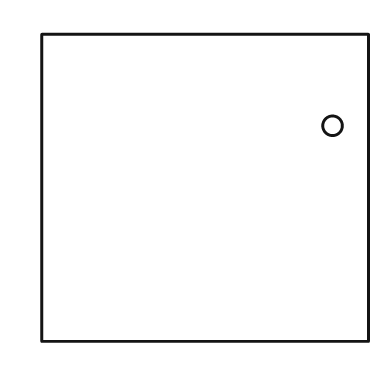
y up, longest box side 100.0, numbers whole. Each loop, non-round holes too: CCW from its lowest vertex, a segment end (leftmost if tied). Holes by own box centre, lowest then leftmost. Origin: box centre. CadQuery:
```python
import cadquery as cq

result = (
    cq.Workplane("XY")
    .moveTo(-50.0, -47.0)
    .lineTo(50.0, -47.0)
    .lineTo(50.0, 47.0)
    .lineTo(-50.0, 47.0)
    .close()
    .moveTo(39.0, 19.0)
    .circle(3.0)
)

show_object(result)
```